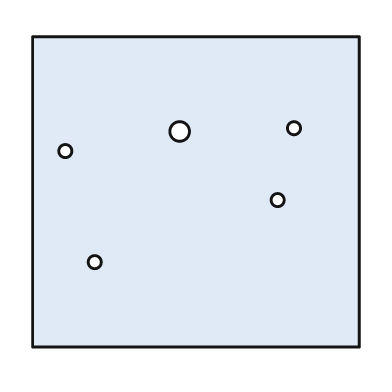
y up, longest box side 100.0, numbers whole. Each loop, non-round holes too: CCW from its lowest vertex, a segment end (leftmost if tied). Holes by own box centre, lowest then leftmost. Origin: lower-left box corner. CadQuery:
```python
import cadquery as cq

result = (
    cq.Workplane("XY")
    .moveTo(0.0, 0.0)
    .lineTo(100.0, 0.0)
    .lineTo(100.0, 95.0)
    .lineTo(0.0, 95.0)
    .close()
    .moveTo(19.0, 26.0)
    .circle(2.0)
    .moveTo(75.0, 45.0)
    .circle(2.0)
    .moveTo(10.0, 60.0)
    .circle(2.0)
    .moveTo(45.0, 66.0)
    .circle(3.0)
    .moveTo(80.0, 67.0)
    .circle(2.0)
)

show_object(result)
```